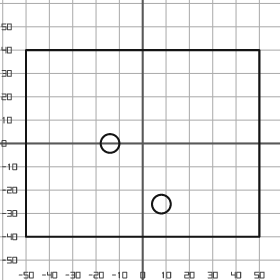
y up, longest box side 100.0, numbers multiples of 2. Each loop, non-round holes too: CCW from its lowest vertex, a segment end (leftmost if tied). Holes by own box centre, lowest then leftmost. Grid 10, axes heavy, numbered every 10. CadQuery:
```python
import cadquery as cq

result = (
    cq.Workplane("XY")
    .moveTo(-50.0, -40.0)
    .lineTo(50.0, -40.0)
    .lineTo(50.0, 40.0)
    .lineTo(-50.0, 40.0)
    .close()
    .moveTo(8.0, -26.0)
    .circle(4.0)
    .moveTo(-14.0, 0.0)
    .circle(4.0)
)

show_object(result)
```